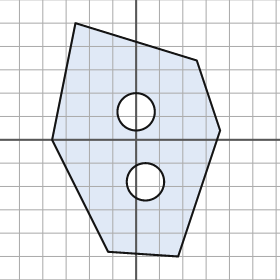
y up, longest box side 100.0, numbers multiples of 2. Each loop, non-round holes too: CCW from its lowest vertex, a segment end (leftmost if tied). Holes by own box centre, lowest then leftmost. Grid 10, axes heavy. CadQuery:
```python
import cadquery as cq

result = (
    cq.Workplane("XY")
    .moveTo(18.0, -50.0)
    .lineTo(36.0, 4.0)
    .lineTo(26.0, 34.0)
    .lineTo(-26.0, 50.0)
    .lineTo(-36.0, 0.0)
    .lineTo(-12.0, -48.0)
    .close()
    .moveTo(4.0, -18.0)
    .circle(8.0)
    .moveTo(0.0, 12.0)
    .circle(8.0)
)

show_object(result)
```